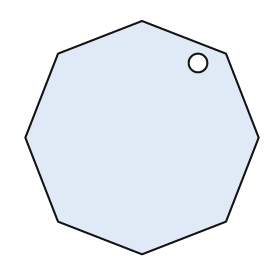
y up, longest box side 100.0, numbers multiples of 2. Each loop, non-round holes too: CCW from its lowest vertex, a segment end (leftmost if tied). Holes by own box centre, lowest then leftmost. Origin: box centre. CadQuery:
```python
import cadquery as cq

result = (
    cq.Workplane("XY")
    .moveTo(0.0, -50.0)
    .lineTo(36.0, -36.0)
    .lineTo(50.0, 0.0)
    .lineTo(36.0, 36.0)
    .lineTo(0.0, 50.0)
    .lineTo(-36.0, 36.0)
    .lineTo(-50.0, 0.0)
    .lineTo(-36.0, -36.0)
    .close()
    .moveTo(24.0, 32.0)
    .circle(4.0)
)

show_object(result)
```